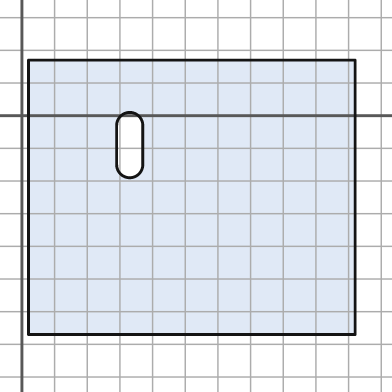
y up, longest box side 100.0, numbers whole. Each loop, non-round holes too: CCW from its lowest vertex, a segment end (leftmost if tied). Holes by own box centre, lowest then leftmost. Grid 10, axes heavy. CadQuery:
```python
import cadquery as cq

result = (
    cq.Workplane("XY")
    .moveTo(2.0, -67.0)
    .lineTo(102.0, -67.0)
    .lineTo(102.0, 17.0)
    .lineTo(2.0, 17.0)
    .close()
    .moveTo(29.0, -15.0)
    .threePointArc((33.0, -19.0), (37.0, -15.0))
    .lineTo(37.0, -3.0)
    .threePointArc((33.0, 1.0), (29.0, -3.0))
    .close()
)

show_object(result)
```